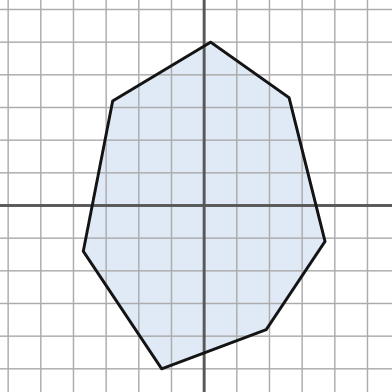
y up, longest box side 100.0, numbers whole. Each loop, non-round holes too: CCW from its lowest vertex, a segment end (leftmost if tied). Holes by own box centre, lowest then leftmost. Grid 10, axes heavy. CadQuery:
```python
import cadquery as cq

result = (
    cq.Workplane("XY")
    .moveTo(-13.0, -50.0)
    .lineTo(19.0, -38.0)
    .lineTo(37.0, -11.0)
    .lineTo(26.0, 33.0)
    .lineTo(2.0, 50.0)
    .lineTo(-28.0, 32.0)
    .lineTo(-37.0, -14.0)
    .close()
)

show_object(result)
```